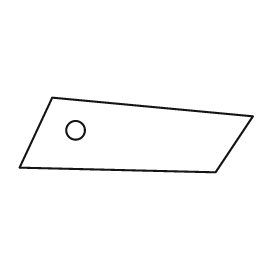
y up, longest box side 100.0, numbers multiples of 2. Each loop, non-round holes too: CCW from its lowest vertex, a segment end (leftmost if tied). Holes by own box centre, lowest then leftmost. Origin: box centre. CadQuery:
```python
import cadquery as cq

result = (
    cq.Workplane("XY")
    .moveTo(34.0, -16.0)
    .lineTo(50.0, 8.0)
    .lineTo(-36.0, 16.0)
    .lineTo(-50.0, -14.0)
    .close()
    .moveTo(-26.0, 2.0)
    .circle(4.0)
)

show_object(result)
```